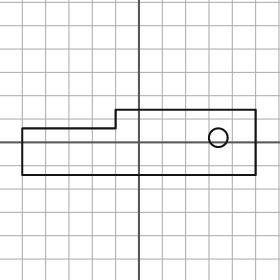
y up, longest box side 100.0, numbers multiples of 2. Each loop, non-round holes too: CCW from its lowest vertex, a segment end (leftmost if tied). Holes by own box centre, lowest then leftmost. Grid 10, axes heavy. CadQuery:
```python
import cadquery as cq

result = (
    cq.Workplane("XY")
    .moveTo(-50.0, -14.0)
    .lineTo(50.0, -14.0)
    .lineTo(50.0, 14.0)
    .lineTo(-10.0, 14.0)
    .lineTo(-10.0, 6.0)
    .lineTo(-50.0, 6.0)
    .close()
    .moveTo(34.0, 2.0)
    .circle(4.0)
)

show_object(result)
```